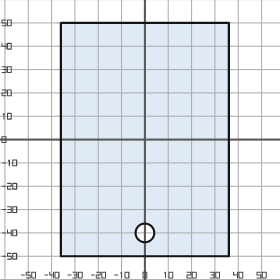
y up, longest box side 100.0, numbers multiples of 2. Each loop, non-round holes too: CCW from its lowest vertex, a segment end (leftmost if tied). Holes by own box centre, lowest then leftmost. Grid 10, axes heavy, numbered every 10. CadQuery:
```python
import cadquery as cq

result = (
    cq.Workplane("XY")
    .moveTo(-36.0, -50.0)
    .lineTo(36.0, -50.0)
    .lineTo(36.0, 50.0)
    .lineTo(-36.0, 50.0)
    .close()
    .moveTo(0.0, -40.0)
    .circle(4.0)
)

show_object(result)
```